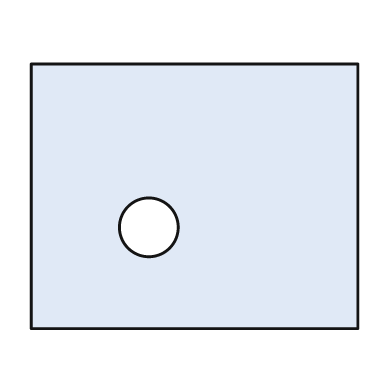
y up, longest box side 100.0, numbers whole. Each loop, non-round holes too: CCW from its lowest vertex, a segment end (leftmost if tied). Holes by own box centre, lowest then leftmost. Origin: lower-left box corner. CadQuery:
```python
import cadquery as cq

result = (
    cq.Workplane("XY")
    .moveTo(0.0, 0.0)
    .lineTo(100.0, 0.0)
    .lineTo(100.0, 81.0)
    .lineTo(0.0, 81.0)
    .close()
    .moveTo(36.0, 31.0)
    .circle(9.0)
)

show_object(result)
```